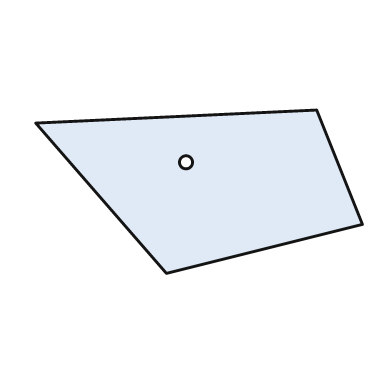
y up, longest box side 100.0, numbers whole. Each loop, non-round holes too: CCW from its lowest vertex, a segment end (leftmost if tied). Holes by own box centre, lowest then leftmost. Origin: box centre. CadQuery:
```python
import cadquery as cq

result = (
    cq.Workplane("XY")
    .moveTo(-10.0, -25.0)
    .lineTo(50.0, -10.0)
    .lineTo(36.0, 25.0)
    .lineTo(-50.0, 21.0)
    .close()
    .moveTo(-4.0, 9.0)
    .circle(2.0)
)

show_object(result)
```